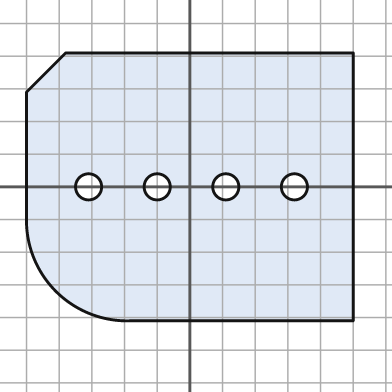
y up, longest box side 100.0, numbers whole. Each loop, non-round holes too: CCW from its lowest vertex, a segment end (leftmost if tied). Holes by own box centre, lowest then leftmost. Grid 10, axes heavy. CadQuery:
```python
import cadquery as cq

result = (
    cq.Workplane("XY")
    .moveTo(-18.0, -41.0)
    .lineTo(50.0, -41.0)
    .lineTo(50.0, 41.0)
    .lineTo(-38.0, 41.0)
    .lineTo(-50.0, 29.0)
    .lineTo(-50.0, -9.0)
    .threePointArc((-41.0, -32.0), (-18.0, -41.0))
    .close()
    .moveTo(-31.0, 0.0)
    .circle(4.0)
    .moveTo(-10.0, 0.0)
    .circle(4.0)
    .moveTo(11.0, 0.0)
    .circle(4.0)
    .moveTo(32.0, 0.0)
    .circle(4.0)
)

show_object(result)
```